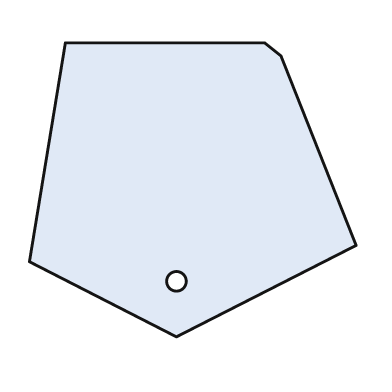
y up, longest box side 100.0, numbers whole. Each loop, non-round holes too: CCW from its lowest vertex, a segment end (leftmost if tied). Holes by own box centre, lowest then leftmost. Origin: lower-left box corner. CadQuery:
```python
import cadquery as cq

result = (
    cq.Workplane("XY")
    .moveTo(45.0, 0.0)
    .lineTo(100.0, 28.0)
    .lineTo(77.0, 86.0)
    .lineTo(72.0, 90.0)
    .lineTo(11.0, 90.0)
    .lineTo(0.0, 23.0)
    .close()
    .moveTo(45.0, 17.0)
    .circle(3.0)
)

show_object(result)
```